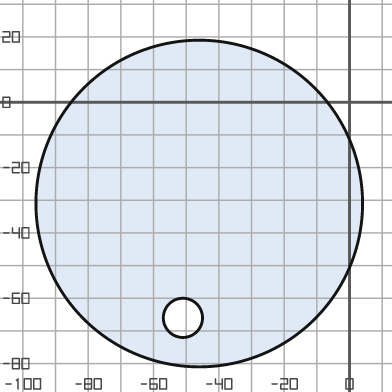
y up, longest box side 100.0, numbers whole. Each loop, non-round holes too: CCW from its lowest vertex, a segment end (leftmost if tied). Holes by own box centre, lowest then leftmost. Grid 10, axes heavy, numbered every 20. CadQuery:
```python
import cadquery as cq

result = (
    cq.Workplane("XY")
    .moveTo(-46.0, -31.0)
    .circle(50.0)
    .moveTo(-51.0, -66.0)
    .circle(6.0)
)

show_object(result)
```